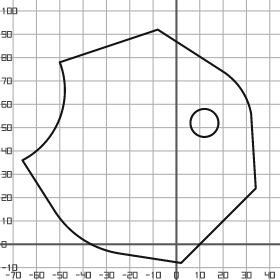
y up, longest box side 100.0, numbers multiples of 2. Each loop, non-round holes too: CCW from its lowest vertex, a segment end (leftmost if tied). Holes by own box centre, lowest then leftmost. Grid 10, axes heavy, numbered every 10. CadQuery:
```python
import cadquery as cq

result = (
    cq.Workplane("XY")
    .moveTo(2.0, -8.0)
    .lineTo(34.0, 24.0)
    .lineTo(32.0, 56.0)
    .threePointArc((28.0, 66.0), (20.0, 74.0))
    .lineTo(-8.0, 92.0)
    .lineTo(-50.0, 78.0)
    .threePointArc((-50.0, 54.0), (-66.0, 36.0))
    .lineTo(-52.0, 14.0)
    .threePointArc((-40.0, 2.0), (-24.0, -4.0))
    .close()
    .moveTo(12.0, 52.0)
    .circle(6.0)
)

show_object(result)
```